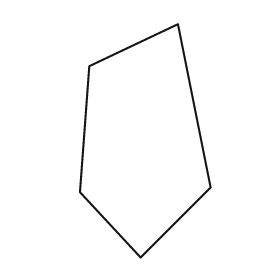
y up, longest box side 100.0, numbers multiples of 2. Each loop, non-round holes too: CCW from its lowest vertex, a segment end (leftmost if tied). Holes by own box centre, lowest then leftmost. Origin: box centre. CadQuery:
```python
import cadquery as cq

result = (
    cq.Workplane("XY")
    .moveTo(-2.0, -50.0)
    .lineTo(28.0, -20.0)
    .lineTo(14.0, 50.0)
    .lineTo(-24.0, 32.0)
    .lineTo(-28.0, -22.0)
    .close()
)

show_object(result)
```